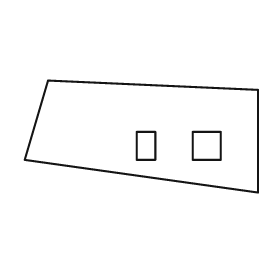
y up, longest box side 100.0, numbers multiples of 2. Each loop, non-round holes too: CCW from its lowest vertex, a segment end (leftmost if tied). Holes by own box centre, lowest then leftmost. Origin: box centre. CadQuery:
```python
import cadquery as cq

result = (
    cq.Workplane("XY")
    .moveTo(50.0, -24.0)
    .lineTo(50.0, 20.0)
    .lineTo(-40.0, 24.0)
    .lineTo(-50.0, -10.0)
    .close()
    .moveTo(-2.0, -10.0)
    .lineTo(6.0, -10.0)
    .lineTo(6.0, 2.0)
    .lineTo(-2.0, 2.0)
    .close()
    .moveTo(22.0, -10.0)
    .lineTo(34.0, -10.0)
    .lineTo(34.0, 2.0)
    .lineTo(22.0, 2.0)
    .close()
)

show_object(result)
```